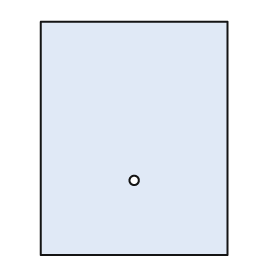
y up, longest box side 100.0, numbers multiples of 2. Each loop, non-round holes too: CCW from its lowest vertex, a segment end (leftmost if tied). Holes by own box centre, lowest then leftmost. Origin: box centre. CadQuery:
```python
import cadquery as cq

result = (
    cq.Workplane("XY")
    .moveTo(-40.0, -50.0)
    .lineTo(40.0, -50.0)
    .lineTo(40.0, 50.0)
    .lineTo(-40.0, 50.0)
    .close()
    .moveTo(0.0, -18.0)
    .circle(2.0)
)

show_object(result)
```